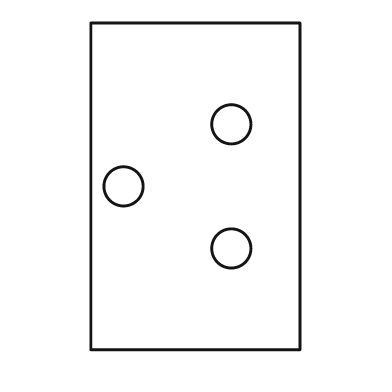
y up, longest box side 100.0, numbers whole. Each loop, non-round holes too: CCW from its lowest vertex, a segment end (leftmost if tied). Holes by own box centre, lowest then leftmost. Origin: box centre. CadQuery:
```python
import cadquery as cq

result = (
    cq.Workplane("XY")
    .moveTo(-32.0, -50.0)
    .lineTo(32.0, -50.0)
    .lineTo(32.0, 50.0)
    .lineTo(-32.0, 50.0)
    .close()
    .moveTo(11.0, -19.0)
    .circle(6.0)
    .moveTo(-22.0, 0.0)
    .circle(6.0)
    .moveTo(11.0, 19.0)
    .circle(6.0)
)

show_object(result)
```